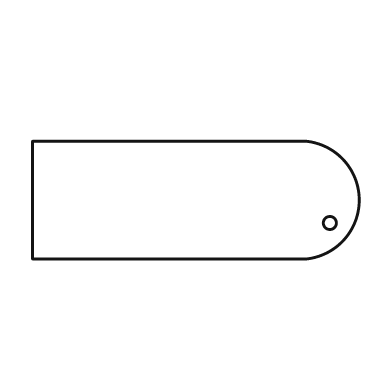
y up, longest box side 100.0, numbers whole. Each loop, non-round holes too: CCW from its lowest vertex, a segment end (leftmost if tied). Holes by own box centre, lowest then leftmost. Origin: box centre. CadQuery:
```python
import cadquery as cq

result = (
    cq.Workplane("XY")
    .moveTo(-50.0, -18.0)
    .lineTo(34.0, -18.0)
    .threePointArc((50.0, 0.0), (34.0, 18.0))
    .lineTo(-50.0, 18.0)
    .close()
    .moveTo(41.0, -7.0)
    .circle(2.0)
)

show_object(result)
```